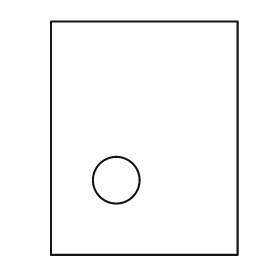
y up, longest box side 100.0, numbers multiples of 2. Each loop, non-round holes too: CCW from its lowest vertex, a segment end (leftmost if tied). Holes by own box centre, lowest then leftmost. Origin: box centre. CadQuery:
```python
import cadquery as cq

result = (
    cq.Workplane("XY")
    .moveTo(-40.0, -50.0)
    .lineTo(40.0, -50.0)
    .lineTo(40.0, 50.0)
    .lineTo(-40.0, 50.0)
    .close()
    .moveTo(-12.0, -18.0)
    .circle(10.0)
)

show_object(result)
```